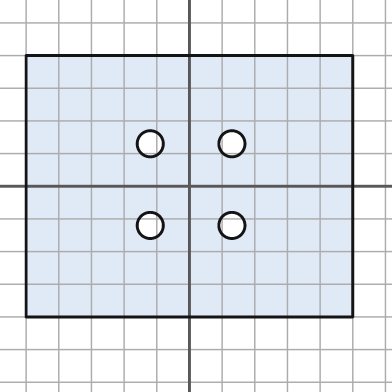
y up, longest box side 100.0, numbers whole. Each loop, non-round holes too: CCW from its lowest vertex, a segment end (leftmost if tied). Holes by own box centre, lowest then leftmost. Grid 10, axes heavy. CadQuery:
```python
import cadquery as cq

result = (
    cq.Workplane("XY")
    .moveTo(-50.0, -40.0)
    .lineTo(50.0, -40.0)
    .lineTo(50.0, 40.0)
    .lineTo(-50.0, 40.0)
    .close()
    .moveTo(-12.0, -12.0)
    .circle(4.0)
    .moveTo(13.0, -12.0)
    .circle(4.0)
    .moveTo(-12.0, 13.0)
    .circle(4.0)
    .moveTo(13.0, 13.0)
    .circle(4.0)
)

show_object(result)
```